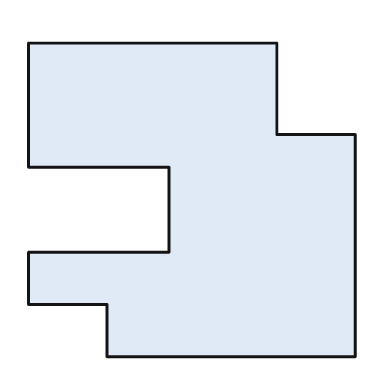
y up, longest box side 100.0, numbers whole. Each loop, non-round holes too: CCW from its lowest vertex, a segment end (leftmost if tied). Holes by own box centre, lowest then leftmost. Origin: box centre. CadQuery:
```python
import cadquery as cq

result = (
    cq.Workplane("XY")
    .moveTo(-26.0, -48.0)
    .lineTo(50.0, -48.0)
    .lineTo(50.0, 20.0)
    .lineTo(26.0, 20.0)
    .lineTo(26.0, 48.0)
    .lineTo(-50.0, 48.0)
    .lineTo(-50.0, 10.0)
    .lineTo(-7.0, 10.0)
    .lineTo(-7.0, -16.0)
    .lineTo(-50.0, -16.0)
    .lineTo(-50.0, -32.0)
    .lineTo(-26.0, -32.0)
    .close()
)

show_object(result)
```